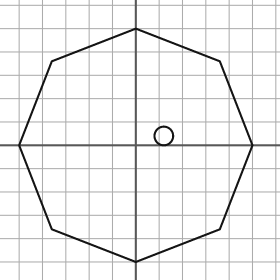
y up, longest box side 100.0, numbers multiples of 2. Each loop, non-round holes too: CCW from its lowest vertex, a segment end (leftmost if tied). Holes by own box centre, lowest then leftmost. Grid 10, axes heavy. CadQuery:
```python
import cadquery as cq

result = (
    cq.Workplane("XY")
    .moveTo(0.0, -50.0)
    .lineTo(36.0, -36.0)
    .lineTo(50.0, 0.0)
    .lineTo(36.0, 36.0)
    .lineTo(0.0, 50.0)
    .lineTo(-36.0, 36.0)
    .lineTo(-50.0, 0.0)
    .lineTo(-36.0, -36.0)
    .close()
    .moveTo(12.0, 4.0)
    .circle(4.0)
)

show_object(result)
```